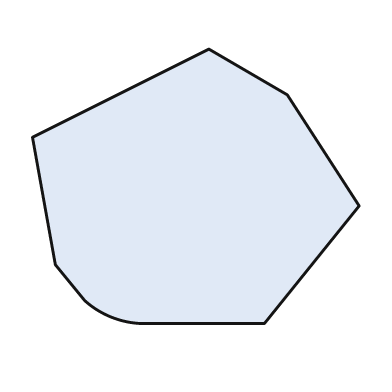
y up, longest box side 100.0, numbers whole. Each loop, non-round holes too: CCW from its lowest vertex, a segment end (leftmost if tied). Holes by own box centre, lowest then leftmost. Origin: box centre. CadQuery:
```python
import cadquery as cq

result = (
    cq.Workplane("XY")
    .moveTo(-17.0, -42.0)
    .lineTo(21.0, -42.0)
    .lineTo(50.0, -6.0)
    .lineTo(28.0, 28.0)
    .lineTo(4.0, 42.0)
    .lineTo(-50.0, 15.0)
    .lineTo(-43.0, -24.0)
    .lineTo(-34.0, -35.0)
    .threePointArc((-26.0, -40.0), (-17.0, -42.0))
    .close()
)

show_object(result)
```